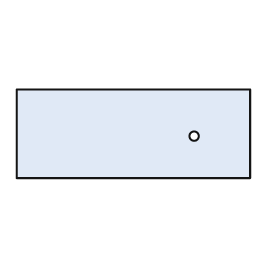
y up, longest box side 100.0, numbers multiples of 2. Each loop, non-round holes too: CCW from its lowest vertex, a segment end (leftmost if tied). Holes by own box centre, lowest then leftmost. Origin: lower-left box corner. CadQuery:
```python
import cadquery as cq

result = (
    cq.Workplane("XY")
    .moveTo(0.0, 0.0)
    .lineTo(100.0, 0.0)
    .lineTo(100.0, 38.0)
    .lineTo(0.0, 38.0)
    .close()
    .moveTo(76.0, 18.0)
    .circle(2.0)
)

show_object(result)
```